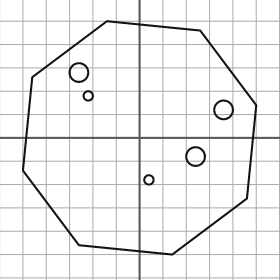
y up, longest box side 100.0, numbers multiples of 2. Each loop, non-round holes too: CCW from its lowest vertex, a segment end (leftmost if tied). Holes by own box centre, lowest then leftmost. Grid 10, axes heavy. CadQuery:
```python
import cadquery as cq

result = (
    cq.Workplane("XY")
    .moveTo(14.0, -50.0)
    .lineTo(46.0, -26.0)
    .lineTo(50.0, 14.0)
    .lineTo(26.0, 46.0)
    .lineTo(-14.0, 50.0)
    .lineTo(-46.0, 26.0)
    .lineTo(-50.0, -14.0)
    .lineTo(-26.0, -46.0)
    .close()
    .moveTo(4.0, -18.0)
    .circle(2.0)
    .moveTo(24.0, -8.0)
    .circle(4.0)
    .moveTo(36.0, 12.0)
    .circle(4.0)
    .moveTo(-22.0, 18.0)
    .circle(2.0)
    .moveTo(-26.0, 28.0)
    .circle(4.0)
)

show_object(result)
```